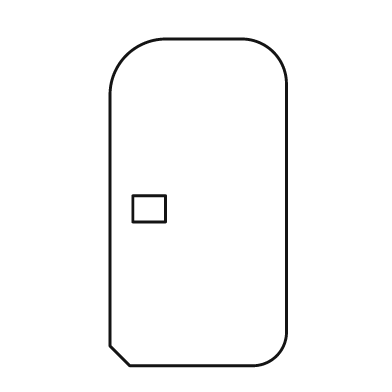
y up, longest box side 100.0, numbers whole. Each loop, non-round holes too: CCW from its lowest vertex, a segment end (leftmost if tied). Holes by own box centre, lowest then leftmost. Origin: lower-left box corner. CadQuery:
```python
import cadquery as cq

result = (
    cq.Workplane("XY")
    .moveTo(6.0, 0.0)
    .lineTo(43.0, 0.0)
    .threePointArc((51.0, 3.0), (54.0, 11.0))
    .lineTo(54.0, 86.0)
    .threePointArc((50.0, 96.0), (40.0, 100.0))
    .lineTo(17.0, 100.0)
    .threePointArc((5.0, 95.0), (0.0, 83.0))
    .lineTo(0.0, 6.0)
    .close()
    .moveTo(7.0, 44.0)
    .lineTo(17.0, 44.0)
    .lineTo(17.0, 52.0)
    .lineTo(7.0, 52.0)
    .close()
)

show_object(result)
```